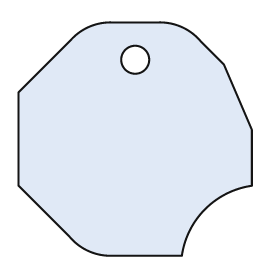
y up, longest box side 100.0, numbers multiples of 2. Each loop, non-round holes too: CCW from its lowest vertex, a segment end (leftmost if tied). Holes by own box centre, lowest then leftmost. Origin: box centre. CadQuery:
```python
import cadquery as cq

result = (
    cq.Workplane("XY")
    .moveTo(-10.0, -50.0)
    .lineTo(20.0, -50.0)
    .threePointArc((30.0, -30.0), (50.0, -20.0))
    .lineTo(50.0, 4.0)
    .lineTo(38.0, 32.0)
    .lineTo(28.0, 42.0)
    .threePointArc((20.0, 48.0), (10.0, 50.0))
    .lineTo(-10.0, 50.0)
    .threePointArc((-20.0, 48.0), (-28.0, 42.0))
    .lineTo(-50.0, 20.0)
    .lineTo(-50.0, -20.0)
    .lineTo(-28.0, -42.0)
    .threePointArc((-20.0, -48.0), (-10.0, -50.0))
    .close()
    .moveTo(0.0, 34.0)
    .circle(6.0)
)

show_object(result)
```